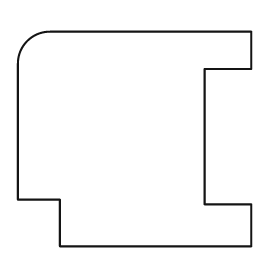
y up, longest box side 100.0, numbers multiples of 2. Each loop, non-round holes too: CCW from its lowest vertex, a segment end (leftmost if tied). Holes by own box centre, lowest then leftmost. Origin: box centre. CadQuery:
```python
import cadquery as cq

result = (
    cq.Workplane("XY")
    .moveTo(-32.0, -46.0)
    .lineTo(50.0, -46.0)
    .lineTo(50.0, -28.0)
    .lineTo(30.0, -28.0)
    .lineTo(30.0, 30.0)
    .lineTo(50.0, 30.0)
    .lineTo(50.0, 46.0)
    .lineTo(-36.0, 46.0)
    .threePointArc((-46.0, 42.0), (-50.0, 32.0))
    .lineTo(-50.0, -26.0)
    .lineTo(-32.0, -26.0)
    .close()
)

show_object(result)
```